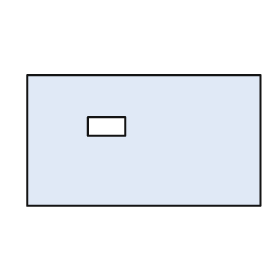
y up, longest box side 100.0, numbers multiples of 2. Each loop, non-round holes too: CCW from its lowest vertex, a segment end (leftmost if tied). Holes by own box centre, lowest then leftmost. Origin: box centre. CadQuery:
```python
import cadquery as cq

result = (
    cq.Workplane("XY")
    .moveTo(-50.0, -28.0)
    .lineTo(50.0, -28.0)
    .lineTo(50.0, 28.0)
    .lineTo(-50.0, 28.0)
    .close()
    .moveTo(-24.0, 2.0)
    .lineTo(-8.0, 2.0)
    .lineTo(-8.0, 10.0)
    .lineTo(-24.0, 10.0)
    .close()
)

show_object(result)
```